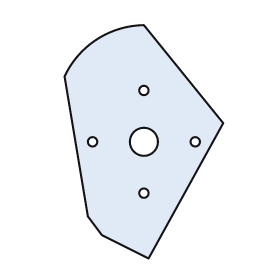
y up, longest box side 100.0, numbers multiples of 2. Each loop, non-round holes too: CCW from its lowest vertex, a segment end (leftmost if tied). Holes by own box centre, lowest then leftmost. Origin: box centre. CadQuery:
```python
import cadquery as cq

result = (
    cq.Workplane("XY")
    .moveTo(2.0, -50.0)
    .lineTo(34.0, 8.0)
    .lineTo(0.0, 50.0)
    .threePointArc((-20.0, 44.0), (-34.0, 28.0))
    .lineTo(-24.0, -32.0)
    .lineTo(-18.0, -40.0)
    .close()
    .moveTo(0.0, -22.0)
    .circle(2.0)
    .moveTo(-22.0, 0.0)
    .circle(2.0)
    .moveTo(0.0, 0.0)
    .circle(6.0)
    .moveTo(22.0, 0.0)
    .circle(2.0)
    .moveTo(0.0, 22.0)
    .circle(2.0)
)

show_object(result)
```